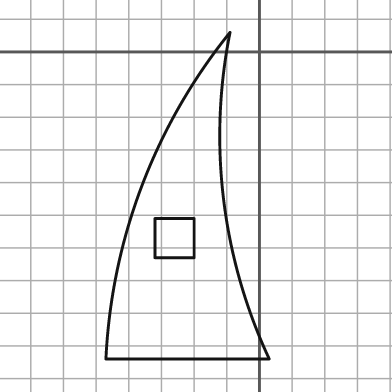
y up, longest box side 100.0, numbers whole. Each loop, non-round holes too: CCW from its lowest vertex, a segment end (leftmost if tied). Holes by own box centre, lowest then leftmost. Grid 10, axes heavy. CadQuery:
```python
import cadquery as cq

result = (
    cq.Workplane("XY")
    .moveTo(-47.0, -94.0)
    .lineTo(3.0, -94.0)
    .threePointArc((-11.0, -45.0), (-9.0, 6.0))
    .threePointArc((-36.0, -41.0), (-47.0, -94.0))
    .close()
    .moveTo(-32.0, -63.0)
    .lineTo(-20.0, -63.0)
    .lineTo(-20.0, -51.0)
    .lineTo(-32.0, -51.0)
    .close()
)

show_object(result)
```